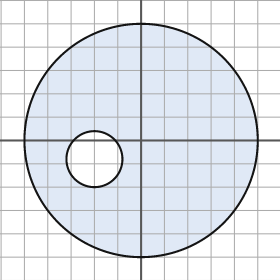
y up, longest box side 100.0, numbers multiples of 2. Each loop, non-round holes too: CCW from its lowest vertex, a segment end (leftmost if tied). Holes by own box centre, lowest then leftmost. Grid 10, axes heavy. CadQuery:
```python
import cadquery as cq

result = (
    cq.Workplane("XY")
    .moveTo(0.0, 0.0)
    .circle(50.0)
    .moveTo(-20.0, -8.0)
    .circle(12.0)
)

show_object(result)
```